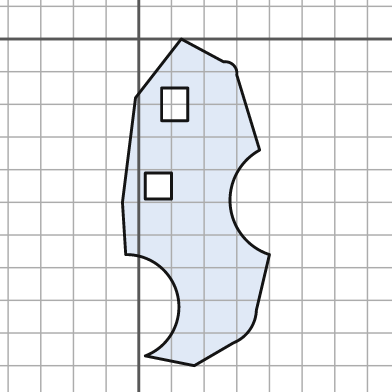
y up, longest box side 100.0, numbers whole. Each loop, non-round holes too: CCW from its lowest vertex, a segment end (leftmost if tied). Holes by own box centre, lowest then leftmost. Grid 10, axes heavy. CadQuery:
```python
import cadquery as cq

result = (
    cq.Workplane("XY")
    .moveTo(17.0, -100.0)
    .lineTo(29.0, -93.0)
    .threePointArc((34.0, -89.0), (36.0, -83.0))
    .lineTo(40.0, -66.0)
    .threePointArc((28.0, -51.0), (37.0, -34.0))
    .lineTo(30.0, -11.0)
    .threePointArc((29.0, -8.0), (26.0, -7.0))
    .lineTo(13.0, 0.0)
    .lineTo(-1.0, -18.0)
    .lineTo(-5.0, -50.0)
    .lineTo(-4.0, -66.0)
    .threePointArc((12.0, -79.0), (2.0, -97.0))
    .close()
    .moveTo(2.0, -49.0)
    .lineTo(10.0, -49.0)
    .lineTo(10.0, -41.0)
    .lineTo(2.0, -41.0)
    .close()
    .moveTo(7.0, -25.0)
    .lineTo(15.0, -25.0)
    .lineTo(15.0, -15.0)
    .lineTo(7.0, -15.0)
    .close()
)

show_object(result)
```